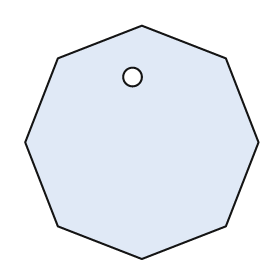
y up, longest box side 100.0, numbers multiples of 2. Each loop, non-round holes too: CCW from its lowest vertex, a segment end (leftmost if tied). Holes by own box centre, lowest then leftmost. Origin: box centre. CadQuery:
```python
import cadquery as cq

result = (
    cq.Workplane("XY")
    .moveTo(0.0, -50.0)
    .lineTo(36.0, -36.0)
    .lineTo(50.0, 0.0)
    .lineTo(36.0, 36.0)
    .lineTo(0.0, 50.0)
    .lineTo(-36.0, 36.0)
    .lineTo(-50.0, 0.0)
    .lineTo(-36.0, -36.0)
    .close()
    .moveTo(-4.0, 28.0)
    .circle(4.0)
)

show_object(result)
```